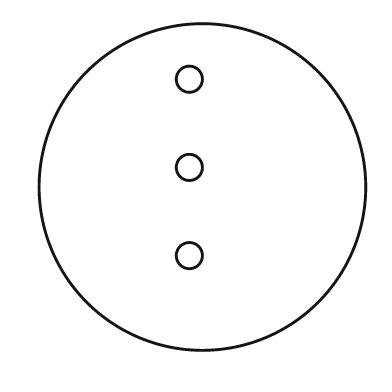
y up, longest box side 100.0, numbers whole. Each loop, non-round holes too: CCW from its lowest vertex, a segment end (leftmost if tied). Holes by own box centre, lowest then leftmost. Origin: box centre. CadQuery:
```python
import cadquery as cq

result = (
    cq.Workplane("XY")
    .moveTo(0.0, 0.0)
    .circle(50.0)
    .moveTo(-4.0, -21.0)
    .circle(4.0)
    .moveTo(-4.0, 6.0)
    .circle(4.0)
    .moveTo(-4.0, 33.0)
    .circle(4.0)
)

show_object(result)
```